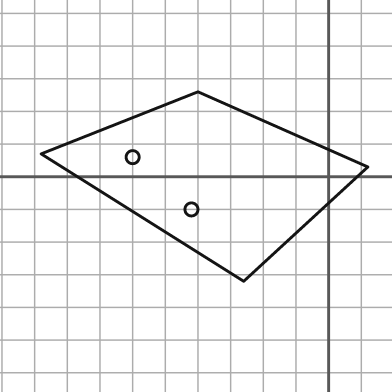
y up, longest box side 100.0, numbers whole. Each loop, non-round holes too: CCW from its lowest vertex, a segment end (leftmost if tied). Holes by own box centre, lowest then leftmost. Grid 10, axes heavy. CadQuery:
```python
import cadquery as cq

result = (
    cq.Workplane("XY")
    .moveTo(-26.0, -32.0)
    .lineTo(12.0, 3.0)
    .lineTo(-40.0, 26.0)
    .lineTo(-88.0, 7.0)
    .close()
    .moveTo(-42.0, -10.0)
    .circle(2.0)
    .moveTo(-60.0, 6.0)
    .circle(2.0)
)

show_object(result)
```